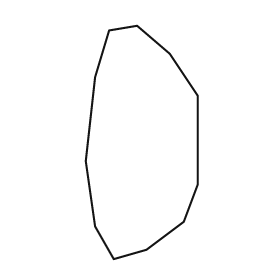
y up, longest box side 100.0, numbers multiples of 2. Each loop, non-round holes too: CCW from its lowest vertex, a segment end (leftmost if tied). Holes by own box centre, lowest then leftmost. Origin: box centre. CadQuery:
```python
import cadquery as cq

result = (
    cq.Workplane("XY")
    .moveTo(-12.0, -50.0)
    .lineTo(2.0, -46.0)
    .lineTo(18.0, -34.0)
    .lineTo(24.0, -18.0)
    .lineTo(24.0, 20.0)
    .lineTo(12.0, 38.0)
    .lineTo(-2.0, 50.0)
    .lineTo(-14.0, 48.0)
    .lineTo(-20.0, 28.0)
    .lineTo(-24.0, -8.0)
    .lineTo(-20.0, -36.0)
    .close()
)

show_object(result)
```